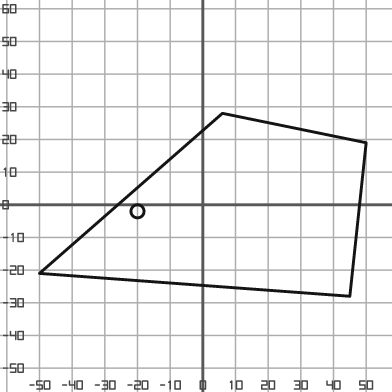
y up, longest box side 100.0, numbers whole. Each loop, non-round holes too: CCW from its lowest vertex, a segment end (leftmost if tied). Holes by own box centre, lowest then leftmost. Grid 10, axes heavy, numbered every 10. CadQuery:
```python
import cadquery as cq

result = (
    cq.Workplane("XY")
    .moveTo(45.0, -28.0)
    .lineTo(50.0, 19.0)
    .lineTo(6.0, 28.0)
    .lineTo(-50.0, -21.0)
    .close()
    .moveTo(-20.0, -2.0)
    .circle(2.0)
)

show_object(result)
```